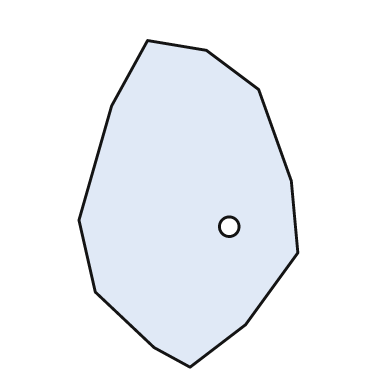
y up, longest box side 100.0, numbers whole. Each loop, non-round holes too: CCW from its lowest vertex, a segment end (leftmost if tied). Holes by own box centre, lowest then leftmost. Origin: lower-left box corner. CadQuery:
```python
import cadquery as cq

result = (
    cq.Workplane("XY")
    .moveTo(34.0, 0.0)
    .lineTo(51.0, 13.0)
    .lineTo(67.0, 35.0)
    .lineTo(65.0, 57.0)
    .lineTo(55.0, 85.0)
    .lineTo(39.0, 97.0)
    .lineTo(21.0, 100.0)
    .lineTo(10.0, 80.0)
    .lineTo(0.0, 45.0)
    .lineTo(5.0, 23.0)
    .lineTo(23.0, 6.0)
    .close()
    .moveTo(46.0, 43.0)
    .circle(3.0)
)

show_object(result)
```